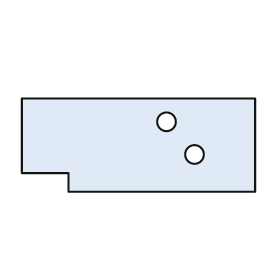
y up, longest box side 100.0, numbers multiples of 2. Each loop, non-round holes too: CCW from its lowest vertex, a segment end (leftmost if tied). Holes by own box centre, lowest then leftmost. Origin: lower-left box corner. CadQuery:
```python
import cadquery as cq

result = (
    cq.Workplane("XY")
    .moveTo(20.0, 0.0)
    .lineTo(100.0, 0.0)
    .lineTo(100.0, 40.0)
    .lineTo(0.0, 40.0)
    .lineTo(0.0, 8.0)
    .lineTo(20.0, 8.0)
    .close()
    .moveTo(74.0, 16.0)
    .circle(4.0)
    .moveTo(62.0, 30.0)
    .circle(4.0)
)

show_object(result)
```